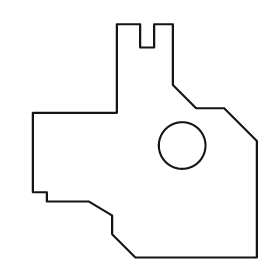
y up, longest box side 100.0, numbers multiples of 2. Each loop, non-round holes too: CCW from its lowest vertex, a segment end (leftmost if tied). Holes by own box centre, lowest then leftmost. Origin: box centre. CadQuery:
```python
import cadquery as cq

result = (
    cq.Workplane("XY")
    .moveTo(-4.0, -50.0)
    .lineTo(48.0, -50.0)
    .lineTo(48.0, 0.0)
    .lineTo(34.0, 14.0)
    .lineTo(22.0, 14.0)
    .lineTo(12.0, 24.0)
    .lineTo(12.0, 50.0)
    .lineTo(4.0, 50.0)
    .lineTo(4.0, 40.0)
    .lineTo(-2.0, 40.0)
    .lineTo(-2.0, 50.0)
    .lineTo(-12.0, 50.0)
    .lineTo(-12.0, 12.0)
    .lineTo(-48.0, 12.0)
    .lineTo(-48.0, -22.0)
    .lineTo(-42.0, -22.0)
    .lineTo(-42.0, -26.0)
    .lineTo(-24.0, -26.0)
    .lineTo(-14.0, -32.0)
    .lineTo(-14.0, -40.0)
    .close()
    .moveTo(16.0, -2.0)
    .circle(10.0)
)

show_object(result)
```